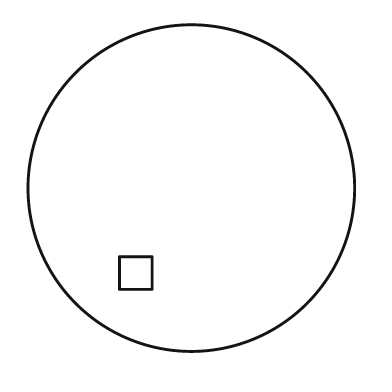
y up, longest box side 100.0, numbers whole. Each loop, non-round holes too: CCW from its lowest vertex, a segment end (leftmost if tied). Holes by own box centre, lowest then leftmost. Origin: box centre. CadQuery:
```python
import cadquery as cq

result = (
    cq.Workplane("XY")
    .moveTo(0.0, 0.0)
    .circle(50.0)
    .moveTo(-22.0, -31.0)
    .lineTo(-12.0, -31.0)
    .lineTo(-12.0, -21.0)
    .lineTo(-22.0, -21.0)
    .close()
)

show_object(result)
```